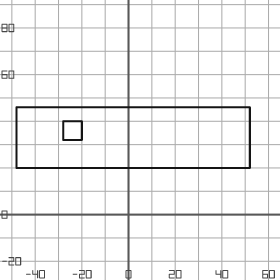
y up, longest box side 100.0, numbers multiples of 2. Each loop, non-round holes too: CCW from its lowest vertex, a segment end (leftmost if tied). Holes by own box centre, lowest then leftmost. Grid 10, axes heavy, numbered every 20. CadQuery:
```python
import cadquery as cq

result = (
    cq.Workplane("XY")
    .moveTo(-48.0, 20.0)
    .lineTo(52.0, 20.0)
    .lineTo(52.0, 46.0)
    .lineTo(-48.0, 46.0)
    .close()
    .moveTo(-28.0, 32.0)
    .lineTo(-20.0, 32.0)
    .lineTo(-20.0, 40.0)
    .lineTo(-28.0, 40.0)
    .close()
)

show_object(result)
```